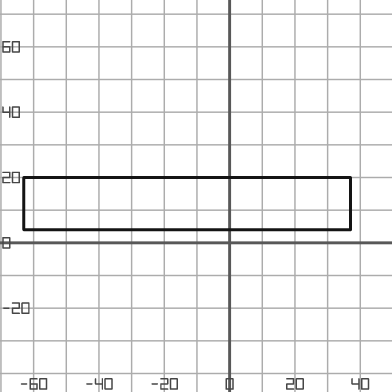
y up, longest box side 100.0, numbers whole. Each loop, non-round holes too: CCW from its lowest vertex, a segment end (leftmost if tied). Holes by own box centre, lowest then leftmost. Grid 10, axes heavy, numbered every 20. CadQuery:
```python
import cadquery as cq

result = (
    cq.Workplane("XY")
    .moveTo(-63.0, 4.0)
    .lineTo(37.0, 4.0)
    .lineTo(37.0, 20.0)
    .lineTo(-63.0, 20.0)
    .close()
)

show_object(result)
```